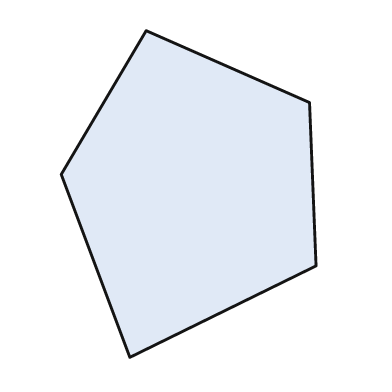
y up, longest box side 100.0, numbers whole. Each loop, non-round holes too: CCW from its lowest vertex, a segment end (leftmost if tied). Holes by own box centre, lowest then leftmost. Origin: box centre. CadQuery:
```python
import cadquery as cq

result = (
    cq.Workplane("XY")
    .moveTo(-18.0, -50.0)
    .lineTo(39.0, -22.0)
    .lineTo(37.0, 28.0)
    .lineTo(-13.0, 50.0)
    .lineTo(-39.0, 6.0)
    .close()
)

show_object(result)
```